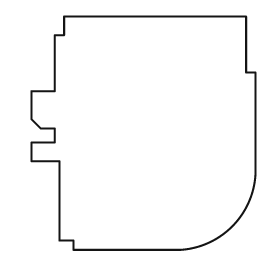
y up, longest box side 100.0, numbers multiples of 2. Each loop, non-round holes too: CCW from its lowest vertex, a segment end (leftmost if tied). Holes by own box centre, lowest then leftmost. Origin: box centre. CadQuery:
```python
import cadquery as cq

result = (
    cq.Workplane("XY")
    .moveTo(-30.0, -50.0)
    .lineTo(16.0, -50.0)
    .threePointArc((38.0, -40.0), (48.0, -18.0))
    .lineTo(48.0, 26.0)
    .lineTo(44.0, 26.0)
    .lineTo(44.0, 50.0)
    .lineTo(-34.0, 50.0)
    .lineTo(-34.0, 42.0)
    .lineTo(-38.0, 42.0)
    .lineTo(-38.0, 18.0)
    .lineTo(-48.0, 18.0)
    .lineTo(-48.0, 6.0)
    .lineTo(-44.0, 2.0)
    .lineTo(-38.0, 2.0)
    .lineTo(-38.0, -4.0)
    .lineTo(-48.0, -4.0)
    .lineTo(-48.0, -12.0)
    .lineTo(-36.0, -12.0)
    .lineTo(-36.0, -46.0)
    .lineTo(-30.0, -46.0)
    .close()
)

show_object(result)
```